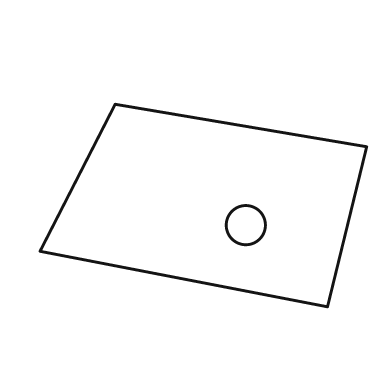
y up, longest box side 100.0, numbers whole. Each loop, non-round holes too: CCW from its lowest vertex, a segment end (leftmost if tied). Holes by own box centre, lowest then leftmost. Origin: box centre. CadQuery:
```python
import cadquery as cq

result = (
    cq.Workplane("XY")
    .moveTo(38.0, -31.0)
    .lineTo(50.0, 18.0)
    .lineTo(-27.0, 31.0)
    .lineTo(-50.0, -14.0)
    .close()
    .moveTo(13.0, -6.0)
    .circle(6.0)
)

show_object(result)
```